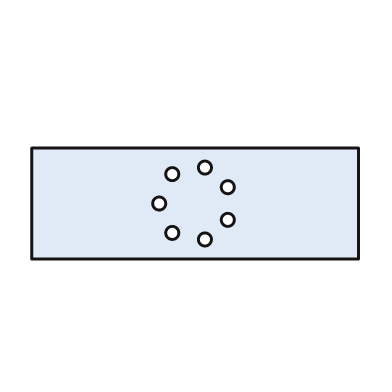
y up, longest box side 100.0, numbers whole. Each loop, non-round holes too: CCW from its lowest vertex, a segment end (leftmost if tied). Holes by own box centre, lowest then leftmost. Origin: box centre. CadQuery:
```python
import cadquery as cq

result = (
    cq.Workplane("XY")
    .moveTo(-50.0, -17.0)
    .lineTo(50.0, -17.0)
    .lineTo(50.0, 17.0)
    .lineTo(-50.0, 17.0)
    .close()
    .moveTo(3.0, -11.0)
    .circle(2.0)
    .moveTo(-7.0, -9.0)
    .circle(2.0)
    .moveTo(10.0, -5.0)
    .circle(2.0)
    .moveTo(-11.0, 0.0)
    .circle(2.0)
    .moveTo(10.0, 5.0)
    .circle(2.0)
    .moveTo(-7.0, 9.0)
    .circle(2.0)
    .moveTo(3.0, 11.0)
    .circle(2.0)
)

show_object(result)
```